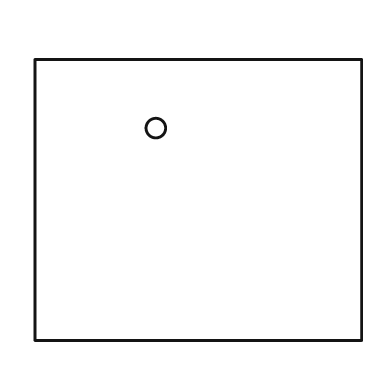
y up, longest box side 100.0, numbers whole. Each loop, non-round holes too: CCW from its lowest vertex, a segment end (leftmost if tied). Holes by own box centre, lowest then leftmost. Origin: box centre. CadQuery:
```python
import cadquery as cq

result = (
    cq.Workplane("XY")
    .moveTo(-50.0, -43.0)
    .lineTo(50.0, -43.0)
    .lineTo(50.0, 43.0)
    .lineTo(-50.0, 43.0)
    .close()
    .moveTo(-13.0, 22.0)
    .circle(3.0)
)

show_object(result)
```